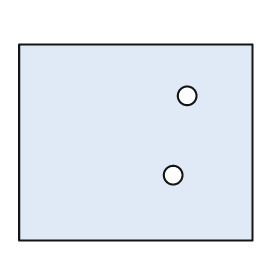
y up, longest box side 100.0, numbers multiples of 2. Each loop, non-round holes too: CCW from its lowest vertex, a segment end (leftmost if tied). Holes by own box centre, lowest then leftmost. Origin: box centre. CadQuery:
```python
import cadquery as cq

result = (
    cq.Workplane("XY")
    .moveTo(-50.0, -42.0)
    .lineTo(50.0, -42.0)
    .lineTo(50.0, 42.0)
    .lineTo(-50.0, 42.0)
    .close()
    .moveTo(16.0, -14.0)
    .circle(4.0)
    .moveTo(22.0, 20.0)
    .circle(4.0)
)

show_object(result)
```